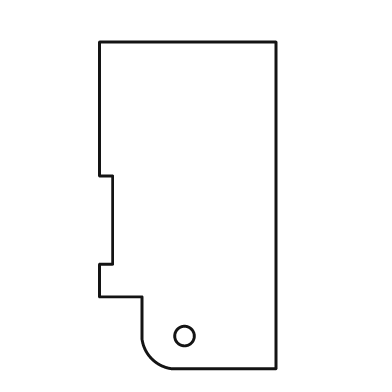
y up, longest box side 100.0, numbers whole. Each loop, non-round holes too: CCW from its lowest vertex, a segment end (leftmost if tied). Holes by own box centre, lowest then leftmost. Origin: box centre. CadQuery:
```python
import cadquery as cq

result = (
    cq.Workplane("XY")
    .moveTo(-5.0, -50.0)
    .lineTo(27.0, -50.0)
    .lineTo(27.0, 50.0)
    .lineTo(-27.0, 50.0)
    .lineTo(-27.0, 9.0)
    .lineTo(-23.0, 9.0)
    .lineTo(-23.0, -18.0)
    .lineTo(-27.0, -18.0)
    .lineTo(-27.0, -28.0)
    .lineTo(-14.0, -28.0)
    .lineTo(-14.0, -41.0)
    .threePointArc((-11.0, -47.0), (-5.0, -50.0))
    .close()
    .moveTo(-1.0, -40.0)
    .circle(3.0)
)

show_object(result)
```